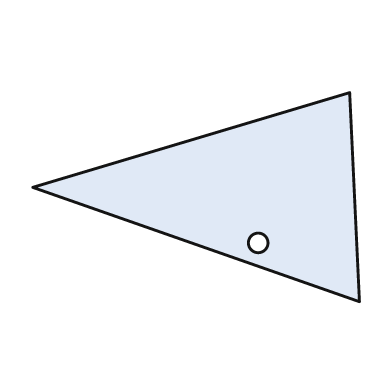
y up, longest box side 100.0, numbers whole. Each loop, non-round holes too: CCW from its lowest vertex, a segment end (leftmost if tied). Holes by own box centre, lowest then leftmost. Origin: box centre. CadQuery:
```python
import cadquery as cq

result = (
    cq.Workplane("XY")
    .moveTo(50.0, -32.0)
    .lineTo(47.0, 32.0)
    .lineTo(-50.0, 3.0)
    .close()
    .moveTo(19.0, -14.0)
    .circle(3.0)
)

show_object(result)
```